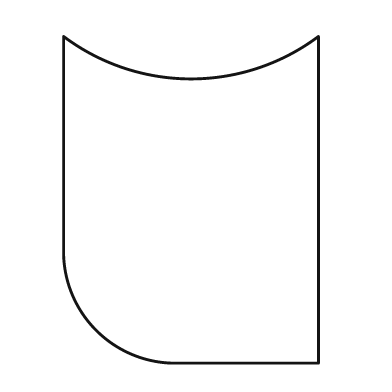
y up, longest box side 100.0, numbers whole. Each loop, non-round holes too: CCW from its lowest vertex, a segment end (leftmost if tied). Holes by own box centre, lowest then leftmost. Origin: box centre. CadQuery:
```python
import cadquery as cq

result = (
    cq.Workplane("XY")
    .moveTo(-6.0, -50.0)
    .lineTo(39.0, -50.0)
    .lineTo(39.0, 50.0)
    .threePointArc((0.0, 37.0), (-39.0, 50.0))
    .lineTo(-39.0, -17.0)
    .threePointArc((-29.0, -40.0), (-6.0, -50.0))
    .close()
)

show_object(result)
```